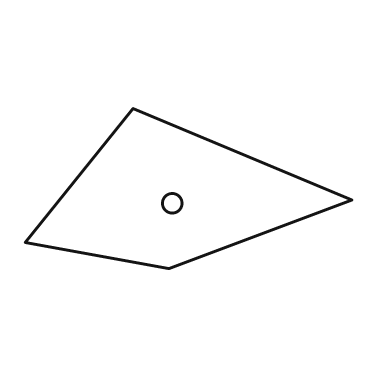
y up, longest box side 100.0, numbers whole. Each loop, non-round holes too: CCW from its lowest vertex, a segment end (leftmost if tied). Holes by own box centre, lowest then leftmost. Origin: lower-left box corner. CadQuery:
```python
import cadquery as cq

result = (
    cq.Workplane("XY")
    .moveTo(44.0, 0.0)
    .lineTo(100.0, 21.0)
    .lineTo(33.0, 49.0)
    .lineTo(0.0, 8.0)
    .close()
    .moveTo(45.0, 20.0)
    .circle(3.0)
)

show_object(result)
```